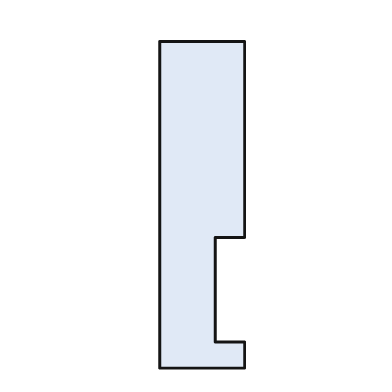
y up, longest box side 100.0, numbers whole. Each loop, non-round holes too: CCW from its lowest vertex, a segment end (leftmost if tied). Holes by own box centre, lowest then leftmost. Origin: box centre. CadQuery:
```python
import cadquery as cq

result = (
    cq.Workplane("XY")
    .moveTo(-13.0, -50.0)
    .lineTo(13.0, -50.0)
    .lineTo(13.0, -42.0)
    .lineTo(4.0, -42.0)
    .lineTo(4.0, -10.0)
    .lineTo(13.0, -10.0)
    .lineTo(13.0, 50.0)
    .lineTo(-13.0, 50.0)
    .close()
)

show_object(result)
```